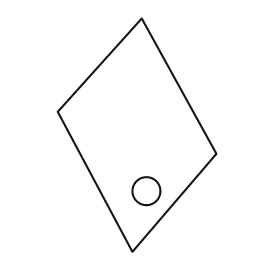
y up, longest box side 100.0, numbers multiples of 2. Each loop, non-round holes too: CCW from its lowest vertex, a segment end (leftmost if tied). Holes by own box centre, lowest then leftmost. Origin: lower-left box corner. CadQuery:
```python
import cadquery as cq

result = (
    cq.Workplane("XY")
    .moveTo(32.0, 0.0)
    .lineTo(68.0, 42.0)
    .lineTo(36.0, 100.0)
    .lineTo(0.0, 60.0)
    .close()
    .moveTo(38.0, 26.0)
    .circle(6.0)
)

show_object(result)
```